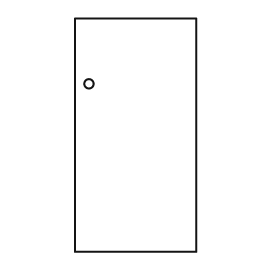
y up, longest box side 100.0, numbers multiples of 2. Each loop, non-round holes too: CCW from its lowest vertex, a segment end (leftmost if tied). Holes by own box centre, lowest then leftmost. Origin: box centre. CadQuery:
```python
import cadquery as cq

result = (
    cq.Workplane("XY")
    .moveTo(-26.0, -50.0)
    .lineTo(26.0, -50.0)
    .lineTo(26.0, 50.0)
    .lineTo(-26.0, 50.0)
    .close()
    .moveTo(-20.0, 22.0)
    .circle(2.0)
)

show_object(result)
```